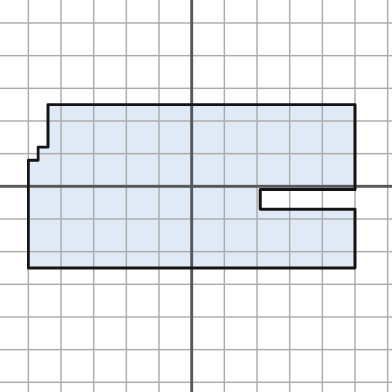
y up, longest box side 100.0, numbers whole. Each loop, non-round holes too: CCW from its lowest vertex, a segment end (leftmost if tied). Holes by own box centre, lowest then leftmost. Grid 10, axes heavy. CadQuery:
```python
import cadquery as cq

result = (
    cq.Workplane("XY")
    .moveTo(-50.0, -25.0)
    .lineTo(50.0, -25.0)
    .lineTo(50.0, -7.0)
    .lineTo(21.0, -7.0)
    .lineTo(21.0, -1.0)
    .lineTo(50.0, -1.0)
    .lineTo(50.0, 25.0)
    .lineTo(-44.0, 25.0)
    .lineTo(-44.0, 12.0)
    .lineTo(-47.0, 12.0)
    .lineTo(-47.0, 8.0)
    .lineTo(-50.0, 8.0)
    .close()
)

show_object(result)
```